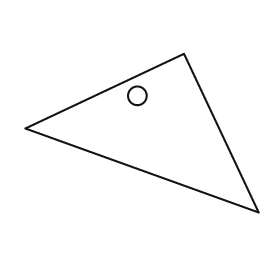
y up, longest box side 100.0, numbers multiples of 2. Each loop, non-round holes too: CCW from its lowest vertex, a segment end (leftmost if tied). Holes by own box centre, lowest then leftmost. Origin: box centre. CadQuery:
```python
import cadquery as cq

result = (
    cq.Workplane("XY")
    .moveTo(50.0, -34.0)
    .lineTo(18.0, 34.0)
    .lineTo(-50.0, 2.0)
    .close()
    .moveTo(-2.0, 16.0)
    .circle(4.0)
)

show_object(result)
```